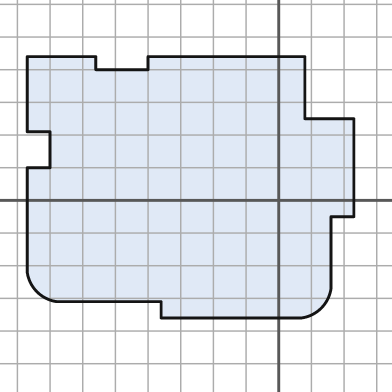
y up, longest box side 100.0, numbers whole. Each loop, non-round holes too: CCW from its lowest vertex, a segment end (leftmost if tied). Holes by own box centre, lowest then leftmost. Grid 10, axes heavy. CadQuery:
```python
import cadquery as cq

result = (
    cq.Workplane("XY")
    .moveTo(-36.0, -36.0)
    .lineTo(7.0, -36.0)
    .threePointArc((13.0, -33.0), (16.0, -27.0))
    .lineTo(16.0, -5.0)
    .lineTo(23.0, -5.0)
    .lineTo(23.0, 25.0)
    .lineTo(8.0, 25.0)
    .lineTo(8.0, 44.0)
    .lineTo(-40.0, 44.0)
    .lineTo(-40.0, 40.0)
    .lineTo(-56.0, 40.0)
    .lineTo(-56.0, 44.0)
    .lineTo(-77.0, 44.0)
    .lineTo(-77.0, 21.0)
    .lineTo(-70.0, 21.0)
    .lineTo(-70.0, 10.0)
    .lineTo(-77.0, 10.0)
    .lineTo(-77.0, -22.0)
    .threePointArc((-74.0, -28.0), (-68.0, -31.0))
    .lineTo(-36.0, -31.0)
    .close()
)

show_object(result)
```